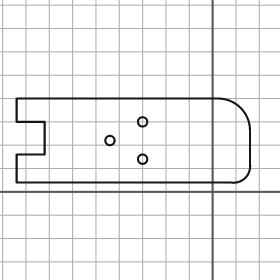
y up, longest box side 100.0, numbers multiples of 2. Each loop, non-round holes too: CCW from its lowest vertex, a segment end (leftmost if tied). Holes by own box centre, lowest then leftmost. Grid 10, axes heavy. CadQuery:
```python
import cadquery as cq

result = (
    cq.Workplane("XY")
    .moveTo(-84.0, 4.0)
    .lineTo(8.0, 4.0)
    .threePointArc((14.0, 6.0), (16.0, 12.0))
    .lineTo(16.0, 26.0)
    .threePointArc((12.0, 36.0), (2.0, 40.0))
    .lineTo(-84.0, 40.0)
    .lineTo(-84.0, 30.0)
    .lineTo(-72.0, 30.0)
    .lineTo(-72.0, 16.0)
    .lineTo(-84.0, 16.0)
    .close()
    .moveTo(-30.0, 14.0)
    .circle(2.0)
    .moveTo(-44.0, 22.0)
    .circle(2.0)
    .moveTo(-30.0, 30.0)
    .circle(2.0)
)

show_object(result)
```